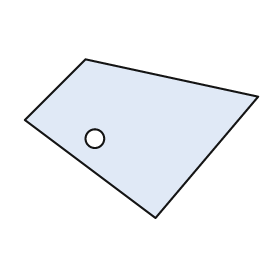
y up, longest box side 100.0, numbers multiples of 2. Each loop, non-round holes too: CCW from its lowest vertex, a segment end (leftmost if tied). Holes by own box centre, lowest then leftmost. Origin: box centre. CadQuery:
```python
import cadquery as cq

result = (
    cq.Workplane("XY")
    .moveTo(6.0, -34.0)
    .lineTo(50.0, 18.0)
    .lineTo(-24.0, 34.0)
    .lineTo(-50.0, 8.0)
    .close()
    .moveTo(-20.0, 0.0)
    .circle(4.0)
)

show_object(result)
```